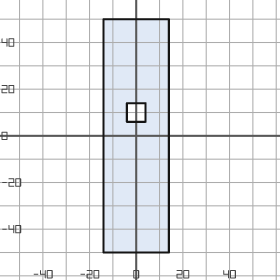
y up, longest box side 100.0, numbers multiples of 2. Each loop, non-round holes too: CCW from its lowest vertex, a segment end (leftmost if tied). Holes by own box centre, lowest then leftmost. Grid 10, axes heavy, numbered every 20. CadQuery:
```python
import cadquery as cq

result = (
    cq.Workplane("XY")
    .moveTo(-14.0, -50.0)
    .lineTo(14.0, -50.0)
    .lineTo(14.0, 50.0)
    .lineTo(-14.0, 50.0)
    .close()
    .moveTo(-4.0, 6.0)
    .lineTo(4.0, 6.0)
    .lineTo(4.0, 14.0)
    .lineTo(-4.0, 14.0)
    .close()
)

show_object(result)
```